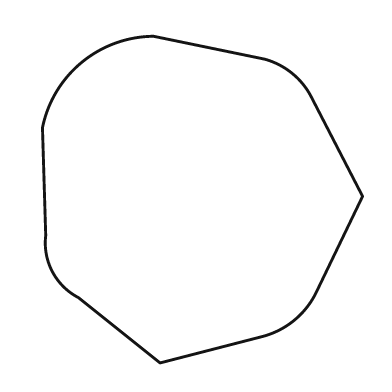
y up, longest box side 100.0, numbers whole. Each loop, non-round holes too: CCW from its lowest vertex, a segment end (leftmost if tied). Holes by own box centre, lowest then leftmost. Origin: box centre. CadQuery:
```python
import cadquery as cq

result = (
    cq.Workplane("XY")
    .moveTo(-13.0, -50.0)
    .lineTo(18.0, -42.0)
    .threePointArc((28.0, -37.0), (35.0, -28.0))
    .lineTo(49.0, 1.0)
    .lineTo(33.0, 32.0)
    .threePointArc((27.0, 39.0), (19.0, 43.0))
    .lineTo(-15.0, 50.0)
    .threePointArc((-37.0, 42.0), (-49.0, 22.0))
    .lineTo(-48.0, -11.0)
    .threePointArc((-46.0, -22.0), (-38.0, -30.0))
    .close()
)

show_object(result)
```